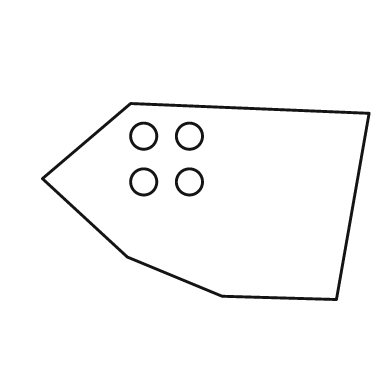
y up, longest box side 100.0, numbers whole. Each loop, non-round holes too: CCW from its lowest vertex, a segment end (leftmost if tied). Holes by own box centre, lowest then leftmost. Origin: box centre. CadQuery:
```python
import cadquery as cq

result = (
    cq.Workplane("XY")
    .moveTo(40.0, -30.0)
    .lineTo(50.0, 27.0)
    .lineTo(-23.0, 30.0)
    .lineTo(-50.0, 7.0)
    .lineTo(-24.0, -17.0)
    .lineTo(5.0, -29.0)
    .close()
    .moveTo(-19.0, 6.0)
    .circle(4.0)
    .moveTo(-5.0, 6.0)
    .circle(4.0)
    .moveTo(-19.0, 20.0)
    .circle(4.0)
    .moveTo(-5.0, 20.0)
    .circle(4.0)
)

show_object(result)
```